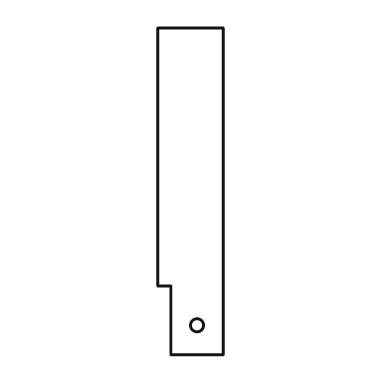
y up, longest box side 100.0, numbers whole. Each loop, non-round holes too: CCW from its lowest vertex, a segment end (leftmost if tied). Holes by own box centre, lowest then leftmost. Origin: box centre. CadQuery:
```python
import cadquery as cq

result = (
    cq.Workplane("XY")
    .moveTo(-6.0, -50.0)
    .lineTo(10.0, -50.0)
    .lineTo(10.0, 50.0)
    .lineTo(-10.0, 50.0)
    .lineTo(-10.0, -29.0)
    .lineTo(-6.0, -29.0)
    .close()
    .moveTo(2.0, -41.0)
    .circle(2.0)
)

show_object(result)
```